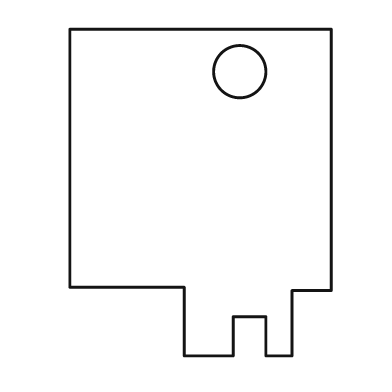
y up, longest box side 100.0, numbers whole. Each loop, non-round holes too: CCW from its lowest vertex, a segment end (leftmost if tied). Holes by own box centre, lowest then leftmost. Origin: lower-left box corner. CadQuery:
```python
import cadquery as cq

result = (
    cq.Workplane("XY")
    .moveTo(35.0, 0.0)
    .lineTo(50.0, 0.0)
    .lineTo(50.0, 12.0)
    .lineTo(60.0, 12.0)
    .lineTo(60.0, 0.0)
    .lineTo(68.0, 0.0)
    .lineTo(68.0, 20.0)
    .lineTo(80.0, 20.0)
    .lineTo(80.0, 100.0)
    .lineTo(0.0, 100.0)
    .lineTo(0.0, 21.0)
    .lineTo(35.0, 21.0)
    .close()
    .moveTo(52.0, 87.0)
    .circle(8.0)
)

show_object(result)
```